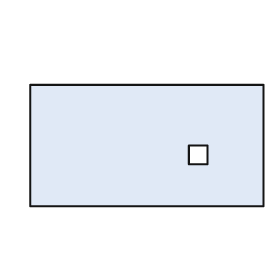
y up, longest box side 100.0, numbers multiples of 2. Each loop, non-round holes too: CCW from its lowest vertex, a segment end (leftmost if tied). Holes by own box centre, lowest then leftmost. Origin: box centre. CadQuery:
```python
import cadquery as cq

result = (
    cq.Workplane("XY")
    .moveTo(-50.0, -26.0)
    .lineTo(50.0, -26.0)
    .lineTo(50.0, 26.0)
    .lineTo(-50.0, 26.0)
    .close()
    .moveTo(18.0, -8.0)
    .lineTo(26.0, -8.0)
    .lineTo(26.0, 0.0)
    .lineTo(18.0, 0.0)
    .close()
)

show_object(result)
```